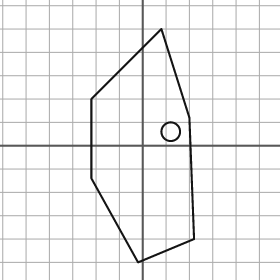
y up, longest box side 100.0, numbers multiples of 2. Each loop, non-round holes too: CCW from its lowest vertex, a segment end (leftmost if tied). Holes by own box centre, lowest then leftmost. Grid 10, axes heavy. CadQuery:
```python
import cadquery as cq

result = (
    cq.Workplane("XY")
    .moveTo(-2.0, -50.0)
    .lineTo(22.0, -40.0)
    .lineTo(20.0, 12.0)
    .lineTo(8.0, 50.0)
    .lineTo(-22.0, 20.0)
    .lineTo(-22.0, -14.0)
    .close()
    .moveTo(12.0, 6.0)
    .circle(4.0)
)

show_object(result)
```